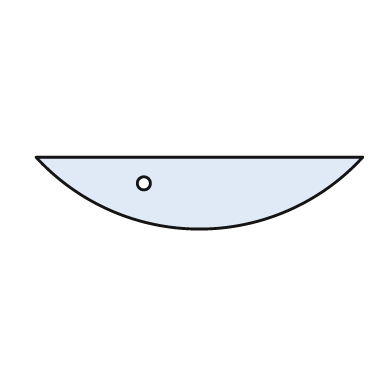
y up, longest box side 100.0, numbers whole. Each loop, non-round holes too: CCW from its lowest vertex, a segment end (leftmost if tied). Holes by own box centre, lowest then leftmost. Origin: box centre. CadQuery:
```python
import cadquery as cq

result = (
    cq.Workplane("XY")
    .moveTo(-50.0, 11.0)
    .threePointArc((0.0, -11.0), (50.0, 11.0))
    .close()
    .moveTo(-17.0, 3.0)
    .circle(2.0)
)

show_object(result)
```